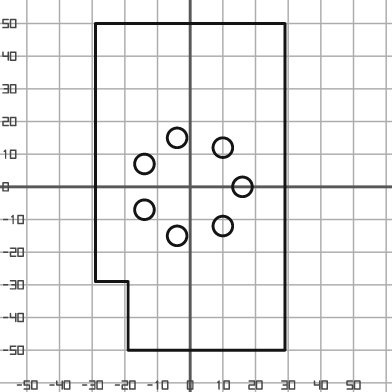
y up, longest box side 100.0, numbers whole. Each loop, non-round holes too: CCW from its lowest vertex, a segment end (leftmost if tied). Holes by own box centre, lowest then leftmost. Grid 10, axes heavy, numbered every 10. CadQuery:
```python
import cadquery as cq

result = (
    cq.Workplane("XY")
    .moveTo(-19.0, -50.0)
    .lineTo(29.0, -50.0)
    .lineTo(29.0, 50.0)
    .lineTo(-29.0, 50.0)
    .lineTo(-29.0, -29.0)
    .lineTo(-19.0, -29.0)
    .close()
    .moveTo(-4.0, -15.0)
    .circle(3.0)
    .moveTo(10.0, -12.0)
    .circle(3.0)
    .moveTo(-14.0, -7.0)
    .circle(3.0)
    .moveTo(16.0, 0.0)
    .circle(3.0)
    .moveTo(-14.0, 7.0)
    .circle(3.0)
    .moveTo(10.0, 12.0)
    .circle(3.0)
    .moveTo(-4.0, 15.0)
    .circle(3.0)
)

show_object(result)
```